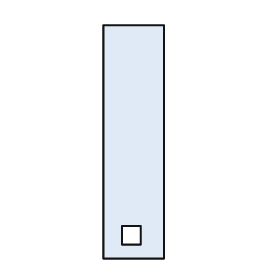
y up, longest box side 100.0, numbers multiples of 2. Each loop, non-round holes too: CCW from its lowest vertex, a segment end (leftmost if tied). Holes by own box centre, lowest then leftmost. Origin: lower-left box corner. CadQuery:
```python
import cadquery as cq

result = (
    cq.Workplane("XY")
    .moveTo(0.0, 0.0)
    .lineTo(26.0, 0.0)
    .lineTo(26.0, 100.0)
    .lineTo(0.0, 100.0)
    .close()
    .moveTo(8.0, 6.0)
    .lineTo(16.0, 6.0)
    .lineTo(16.0, 14.0)
    .lineTo(8.0, 14.0)
    .close()
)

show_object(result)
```